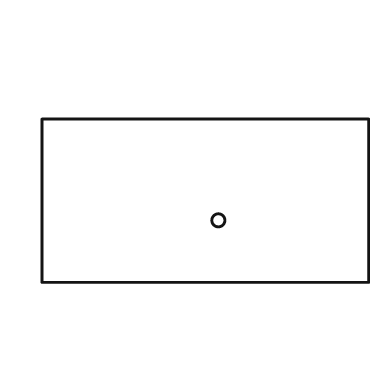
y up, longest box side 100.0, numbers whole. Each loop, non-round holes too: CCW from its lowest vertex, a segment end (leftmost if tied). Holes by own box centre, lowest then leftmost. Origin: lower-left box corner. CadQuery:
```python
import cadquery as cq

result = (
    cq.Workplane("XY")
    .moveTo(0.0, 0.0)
    .lineTo(100.0, 0.0)
    .lineTo(100.0, 50.0)
    .lineTo(0.0, 50.0)
    .close()
    .moveTo(54.0, 19.0)
    .circle(2.0)
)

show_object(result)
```